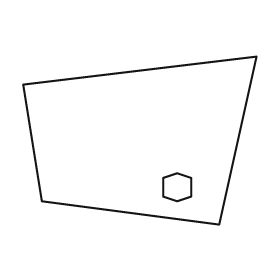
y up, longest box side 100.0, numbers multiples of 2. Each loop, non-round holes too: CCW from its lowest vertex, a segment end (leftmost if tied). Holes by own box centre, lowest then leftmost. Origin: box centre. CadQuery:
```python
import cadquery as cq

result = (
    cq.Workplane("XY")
    .moveTo(34.0, -36.0)
    .lineTo(50.0, 36.0)
    .lineTo(-50.0, 24.0)
    .lineTo(-42.0, -26.0)
    .close()
    .moveTo(16.0, -26.0)
    .lineTo(22.0, -24.0)
    .lineTo(22.0, -16.0)
    .lineTo(16.0, -14.0)
    .lineTo(10.0, -16.0)
    .lineTo(10.0, -24.0)
    .close()
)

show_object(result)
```